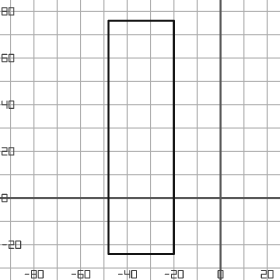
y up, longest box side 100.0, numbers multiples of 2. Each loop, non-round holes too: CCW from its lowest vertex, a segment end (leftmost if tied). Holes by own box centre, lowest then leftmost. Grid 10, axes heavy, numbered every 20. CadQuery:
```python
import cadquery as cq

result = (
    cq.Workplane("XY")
    .moveTo(-48.0, -24.0)
    .lineTo(-20.0, -24.0)
    .lineTo(-20.0, 76.0)
    .lineTo(-48.0, 76.0)
    .close()
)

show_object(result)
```